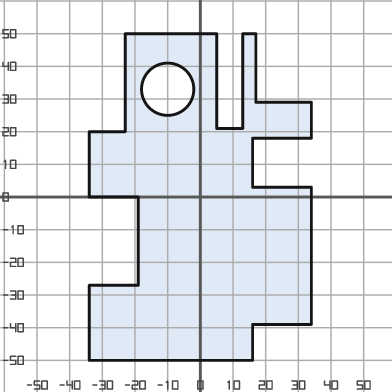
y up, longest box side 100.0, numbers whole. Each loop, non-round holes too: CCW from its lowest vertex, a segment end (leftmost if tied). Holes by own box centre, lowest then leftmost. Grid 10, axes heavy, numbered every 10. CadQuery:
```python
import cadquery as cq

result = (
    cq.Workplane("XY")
    .moveTo(-34.0, -50.0)
    .lineTo(16.0, -50.0)
    .lineTo(16.0, -39.0)
    .lineTo(34.0, -39.0)
    .lineTo(34.0, 3.0)
    .lineTo(16.0, 3.0)
    .lineTo(16.0, 18.0)
    .lineTo(34.0, 18.0)
    .lineTo(34.0, 29.0)
    .lineTo(17.0, 29.0)
    .lineTo(17.0, 50.0)
    .lineTo(13.0, 50.0)
    .lineTo(13.0, 21.0)
    .lineTo(5.0, 21.0)
    .lineTo(5.0, 50.0)
    .lineTo(-23.0, 50.0)
    .lineTo(-23.0, 20.0)
    .lineTo(-34.0, 20.0)
    .lineTo(-34.0, 0.0)
    .lineTo(-19.0, 0.0)
    .lineTo(-19.0, -27.0)
    .lineTo(-34.0, -27.0)
    .close()
    .moveTo(-10.0, 33.0)
    .circle(8.0)
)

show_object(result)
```